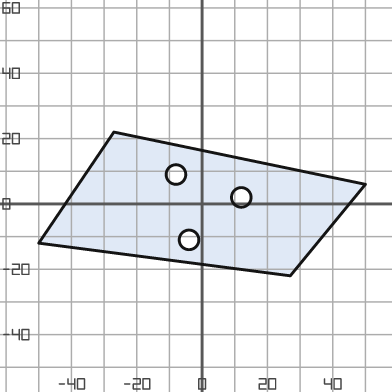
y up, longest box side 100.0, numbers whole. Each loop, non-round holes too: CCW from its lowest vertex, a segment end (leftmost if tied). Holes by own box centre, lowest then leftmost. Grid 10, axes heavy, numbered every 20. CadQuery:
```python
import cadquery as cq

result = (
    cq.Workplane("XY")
    .moveTo(27.0, -22.0)
    .lineTo(50.0, 6.0)
    .lineTo(-27.0, 22.0)
    .lineTo(-50.0, -12.0)
    .close()
    .moveTo(-4.0, -11.0)
    .circle(3.0)
    .moveTo(12.0, 2.0)
    .circle(3.0)
    .moveTo(-8.0, 9.0)
    .circle(3.0)
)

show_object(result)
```